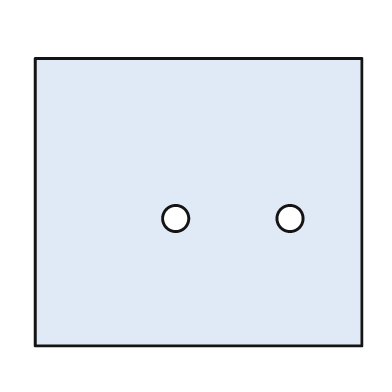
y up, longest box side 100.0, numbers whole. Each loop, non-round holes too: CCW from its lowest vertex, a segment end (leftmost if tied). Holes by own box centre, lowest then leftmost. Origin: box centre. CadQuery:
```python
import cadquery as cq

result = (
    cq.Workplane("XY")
    .moveTo(-50.0, -44.0)
    .lineTo(50.0, -44.0)
    .lineTo(50.0, 44.0)
    .lineTo(-50.0, 44.0)
    .close()
    .moveTo(-7.0, -5.0)
    .circle(4.0)
    .moveTo(28.0, -5.0)
    .circle(4.0)
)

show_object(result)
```